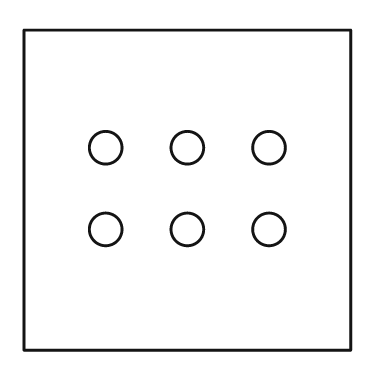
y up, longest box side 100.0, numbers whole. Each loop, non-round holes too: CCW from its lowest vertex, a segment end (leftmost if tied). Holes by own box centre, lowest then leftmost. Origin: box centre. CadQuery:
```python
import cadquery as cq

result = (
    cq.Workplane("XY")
    .moveTo(-50.0, -49.0)
    .lineTo(50.0, -49.0)
    .lineTo(50.0, 49.0)
    .lineTo(-50.0, 49.0)
    .close()
    .moveTo(-25.0, -12.0)
    .circle(5.0)
    .moveTo(0.0, -12.0)
    .circle(5.0)
    .moveTo(25.0, -12.0)
    .circle(5.0)
    .moveTo(-25.0, 13.0)
    .circle(5.0)
    .moveTo(0.0, 13.0)
    .circle(5.0)
    .moveTo(25.0, 13.0)
    .circle(5.0)
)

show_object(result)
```